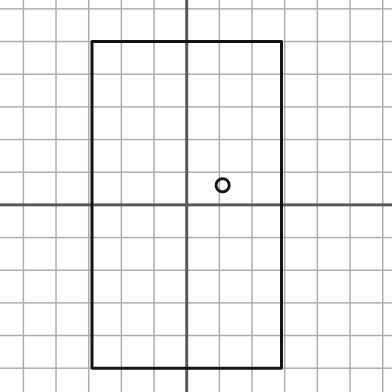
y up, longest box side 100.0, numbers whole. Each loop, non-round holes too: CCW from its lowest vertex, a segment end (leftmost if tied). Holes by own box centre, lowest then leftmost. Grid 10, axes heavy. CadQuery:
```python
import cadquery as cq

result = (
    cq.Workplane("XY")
    .moveTo(-29.0, -50.0)
    .lineTo(29.0, -50.0)
    .lineTo(29.0, 50.0)
    .lineTo(-29.0, 50.0)
    .close()
    .moveTo(11.0, 6.0)
    .circle(2.0)
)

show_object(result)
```